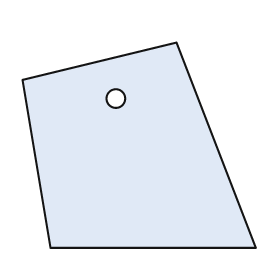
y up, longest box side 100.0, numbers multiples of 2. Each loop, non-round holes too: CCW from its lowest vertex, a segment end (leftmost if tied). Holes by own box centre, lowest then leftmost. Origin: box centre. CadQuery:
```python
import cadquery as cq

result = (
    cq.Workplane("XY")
    .moveTo(-38.0, -44.0)
    .lineTo(50.0, -44.0)
    .lineTo(16.0, 44.0)
    .lineTo(-50.0, 28.0)
    .close()
    .moveTo(-10.0, 20.0)
    .circle(4.0)
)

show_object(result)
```